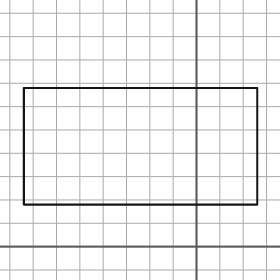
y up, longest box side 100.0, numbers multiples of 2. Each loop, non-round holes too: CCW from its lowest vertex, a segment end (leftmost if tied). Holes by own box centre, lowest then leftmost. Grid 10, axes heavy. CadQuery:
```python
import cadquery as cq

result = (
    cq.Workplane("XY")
    .moveTo(-74.0, 18.0)
    .lineTo(26.0, 18.0)
    .lineTo(26.0, 68.0)
    .lineTo(-74.0, 68.0)
    .close()
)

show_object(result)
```